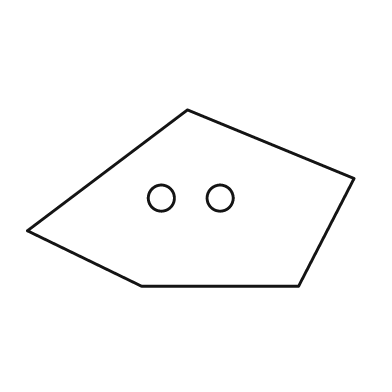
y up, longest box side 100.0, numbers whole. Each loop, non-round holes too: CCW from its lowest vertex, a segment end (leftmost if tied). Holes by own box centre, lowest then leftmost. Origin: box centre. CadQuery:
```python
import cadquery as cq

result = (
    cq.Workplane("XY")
    .moveTo(-15.0, -27.0)
    .lineTo(33.0, -27.0)
    .lineTo(50.0, 6.0)
    .lineTo(-1.0, 27.0)
    .lineTo(-50.0, -10.0)
    .close()
    .moveTo(-9.0, 0.0)
    .circle(4.0)
    .moveTo(9.0, 0.0)
    .circle(4.0)
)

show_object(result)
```